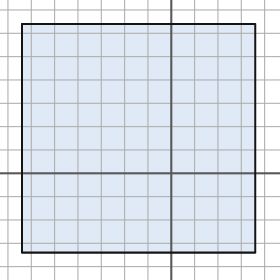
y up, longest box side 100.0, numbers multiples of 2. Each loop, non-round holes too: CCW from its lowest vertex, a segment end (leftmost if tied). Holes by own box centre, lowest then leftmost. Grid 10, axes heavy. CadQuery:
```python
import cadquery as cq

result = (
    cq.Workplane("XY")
    .moveTo(-64.0, -34.0)
    .lineTo(36.0, -34.0)
    .lineTo(36.0, 64.0)
    .lineTo(-64.0, 64.0)
    .close()
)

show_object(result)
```